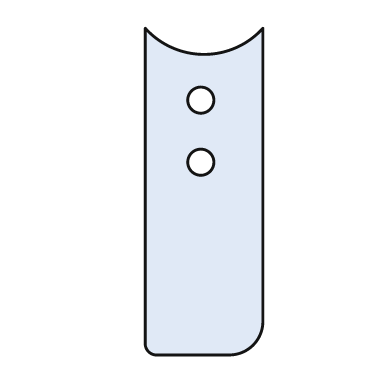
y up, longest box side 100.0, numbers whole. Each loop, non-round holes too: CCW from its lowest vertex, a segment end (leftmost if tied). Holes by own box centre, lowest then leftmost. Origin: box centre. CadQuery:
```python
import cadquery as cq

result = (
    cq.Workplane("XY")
    .moveTo(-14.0, -50.0)
    .lineTo(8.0, -50.0)
    .threePointArc((15.0, -47.0), (18.0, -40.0))
    .lineTo(18.0, 50.0)
    .threePointArc((0.0, 42.0), (-18.0, 50.0))
    .lineTo(-18.0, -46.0)
    .threePointArc((-17.0, -49.0), (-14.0, -50.0))
    .close()
    .moveTo(-1.0, 9.0)
    .circle(4.0)
    .moveTo(-1.0, 28.0)
    .circle(4.0)
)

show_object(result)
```